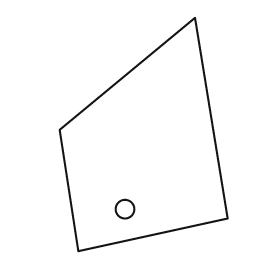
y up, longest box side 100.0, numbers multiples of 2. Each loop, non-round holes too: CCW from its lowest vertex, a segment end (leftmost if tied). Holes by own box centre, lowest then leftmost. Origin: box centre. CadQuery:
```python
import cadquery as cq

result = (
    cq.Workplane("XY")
    .moveTo(-28.0, -50.0)
    .lineTo(36.0, -36.0)
    .lineTo(22.0, 50.0)
    .lineTo(-36.0, 2.0)
    .close()
    .moveTo(-8.0, -32.0)
    .circle(4.0)
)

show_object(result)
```